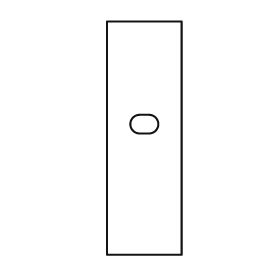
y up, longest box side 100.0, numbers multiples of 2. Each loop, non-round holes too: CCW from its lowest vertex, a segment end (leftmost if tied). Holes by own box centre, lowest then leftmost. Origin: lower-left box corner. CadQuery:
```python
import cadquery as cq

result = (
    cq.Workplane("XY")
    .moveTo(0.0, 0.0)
    .lineTo(32.0, 0.0)
    .lineTo(32.0, 100.0)
    .lineTo(0.0, 100.0)
    .close()
    .moveTo(14.0, 52.0)
    .lineTo(18.0, 52.0)
    .threePointArc((22.0, 56.0), (18.0, 60.0))
    .lineTo(14.0, 60.0)
    .threePointArc((10.0, 56.0), (14.0, 52.0))
    .close()
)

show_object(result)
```